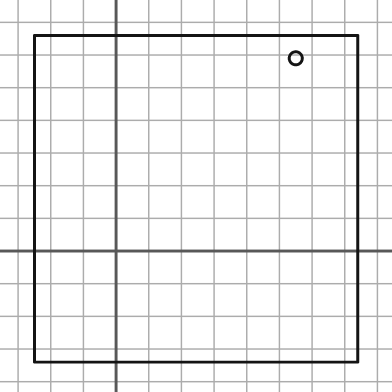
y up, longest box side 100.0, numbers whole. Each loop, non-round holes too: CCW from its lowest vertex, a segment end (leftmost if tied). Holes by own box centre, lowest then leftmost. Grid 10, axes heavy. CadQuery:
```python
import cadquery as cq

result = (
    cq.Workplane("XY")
    .moveTo(-25.0, -34.0)
    .lineTo(74.0, -34.0)
    .lineTo(74.0, 66.0)
    .lineTo(-25.0, 66.0)
    .close()
    .moveTo(55.0, 59.0)
    .circle(2.0)
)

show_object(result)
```